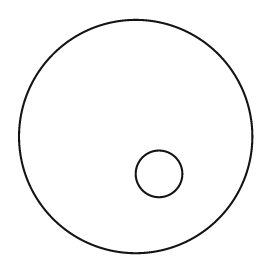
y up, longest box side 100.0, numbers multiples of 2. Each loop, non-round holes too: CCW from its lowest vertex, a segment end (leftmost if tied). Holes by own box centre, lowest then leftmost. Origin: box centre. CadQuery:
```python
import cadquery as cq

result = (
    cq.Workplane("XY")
    .moveTo(0.0, 0.0)
    .circle(50.0)
    .moveTo(10.0, -16.0)
    .circle(10.0)
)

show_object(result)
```